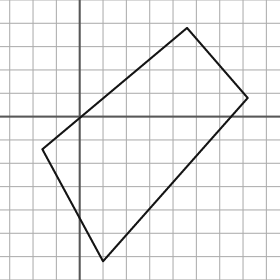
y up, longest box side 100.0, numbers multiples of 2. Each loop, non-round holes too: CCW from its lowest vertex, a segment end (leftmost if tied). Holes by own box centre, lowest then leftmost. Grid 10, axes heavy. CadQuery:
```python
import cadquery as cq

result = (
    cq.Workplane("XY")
    .moveTo(10.0, -62.0)
    .lineTo(72.0, 8.0)
    .lineTo(46.0, 38.0)
    .lineTo(-16.0, -14.0)
    .close()
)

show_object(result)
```